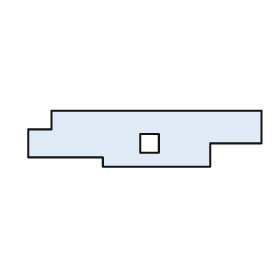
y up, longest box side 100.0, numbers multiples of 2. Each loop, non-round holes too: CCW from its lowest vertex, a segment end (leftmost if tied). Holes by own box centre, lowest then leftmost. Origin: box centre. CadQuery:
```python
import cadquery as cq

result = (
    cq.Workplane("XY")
    .moveTo(-18.0, -12.0)
    .lineTo(28.0, -12.0)
    .lineTo(28.0, -2.0)
    .lineTo(50.0, -2.0)
    .lineTo(50.0, 12.0)
    .lineTo(-40.0, 12.0)
    .lineTo(-40.0, 4.0)
    .lineTo(-50.0, 4.0)
    .lineTo(-50.0, -8.0)
    .lineTo(-18.0, -8.0)
    .close()
    .moveTo(-2.0, -6.0)
    .lineTo(6.0, -6.0)
    .lineTo(6.0, 2.0)
    .lineTo(-2.0, 2.0)
    .close()
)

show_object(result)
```